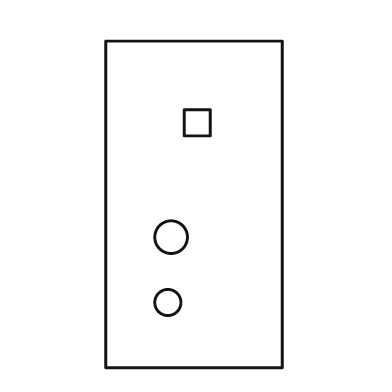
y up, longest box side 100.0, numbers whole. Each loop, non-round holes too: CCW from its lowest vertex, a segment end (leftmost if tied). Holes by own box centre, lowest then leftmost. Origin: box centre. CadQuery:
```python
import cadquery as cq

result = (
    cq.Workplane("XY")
    .moveTo(-27.0, -50.0)
    .lineTo(27.0, -50.0)
    .lineTo(27.0, 50.0)
    .lineTo(-27.0, 50.0)
    .close()
    .moveTo(-8.0, -30.0)
    .circle(4.0)
    .moveTo(-7.0, -10.0)
    .circle(5.0)
    .moveTo(-3.0, 21.0)
    .lineTo(5.0, 21.0)
    .lineTo(5.0, 29.0)
    .lineTo(-3.0, 29.0)
    .close()
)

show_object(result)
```